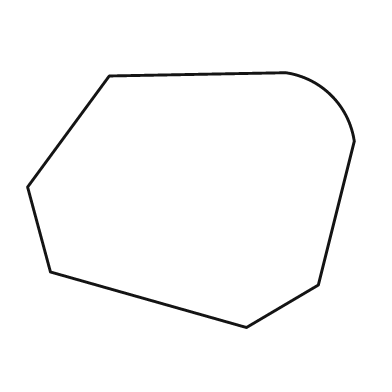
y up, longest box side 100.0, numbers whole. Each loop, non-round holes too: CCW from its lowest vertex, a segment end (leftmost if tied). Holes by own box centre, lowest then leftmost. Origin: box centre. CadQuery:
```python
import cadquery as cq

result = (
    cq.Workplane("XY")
    .moveTo(17.0, -39.0)
    .lineTo(39.0, -26.0)
    .lineTo(50.0, 18.0)
    .threePointArc((43.0, 32.0), (29.0, 39.0))
    .lineTo(-25.0, 38.0)
    .lineTo(-50.0, 4.0)
    .lineTo(-43.0, -22.0)
    .close()
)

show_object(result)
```